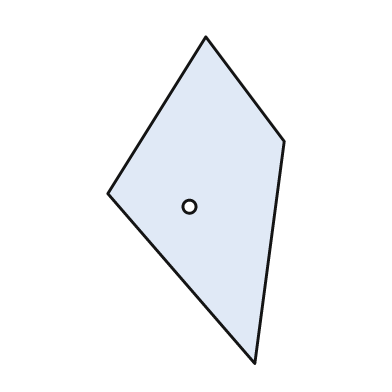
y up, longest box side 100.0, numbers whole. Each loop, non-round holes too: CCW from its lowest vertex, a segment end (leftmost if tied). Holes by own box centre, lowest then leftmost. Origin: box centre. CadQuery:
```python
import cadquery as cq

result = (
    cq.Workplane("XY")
    .moveTo(18.0, -50.0)
    .lineTo(27.0, 18.0)
    .lineTo(3.0, 50.0)
    .lineTo(-27.0, 2.0)
    .close()
    .moveTo(-2.0, -2.0)
    .circle(2.0)
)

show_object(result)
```